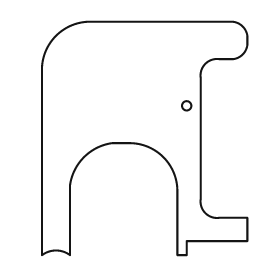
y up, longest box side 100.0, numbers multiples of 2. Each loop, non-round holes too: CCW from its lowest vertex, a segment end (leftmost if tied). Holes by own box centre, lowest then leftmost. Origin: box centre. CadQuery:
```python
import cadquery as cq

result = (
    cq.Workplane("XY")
    .moveTo(-44.0, -50.0)
    .threePointArc((-38.0, -48.0), (-32.0, -50.0))
    .lineTo(-32.0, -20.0)
    .threePointArc((-26.0, -8.0), (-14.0, -2.0))
    .lineTo(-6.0, -2.0)
    .threePointArc((8.0, -8.0), (14.0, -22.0))
    .lineTo(14.0, -50.0)
    .lineTo(18.0, -50.0)
    .lineTo(18.0, -44.0)
    .lineTo(44.0, -44.0)
    .lineTo(44.0, -34.0)
    .lineTo(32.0, -34.0)
    .threePointArc((26.0, -32.0), (24.0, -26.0))
    .lineTo(24.0, 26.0)
    .threePointArc((26.0, 32.0), (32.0, 34.0))
    .lineTo(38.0, 34.0)
    .threePointArc((42.0, 36.0), (44.0, 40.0))
    .lineTo(44.0, 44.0)
    .threePointArc((42.0, 48.0), (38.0, 50.0))
    .lineTo(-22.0, 50.0)
    .threePointArc((-38.0, 44.0), (-44.0, 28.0))
    .close()
    .moveTo(18.0, 14.0)
    .circle(2.0)
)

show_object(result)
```